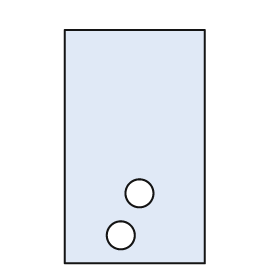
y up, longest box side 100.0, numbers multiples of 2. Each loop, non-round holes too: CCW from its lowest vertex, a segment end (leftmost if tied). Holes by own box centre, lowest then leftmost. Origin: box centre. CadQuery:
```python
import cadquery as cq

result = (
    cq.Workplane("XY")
    .moveTo(-30.0, -50.0)
    .lineTo(30.0, -50.0)
    .lineTo(30.0, 50.0)
    .lineTo(-30.0, 50.0)
    .close()
    .moveTo(-6.0, -38.0)
    .circle(6.0)
    .moveTo(2.0, -20.0)
    .circle(6.0)
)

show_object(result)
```